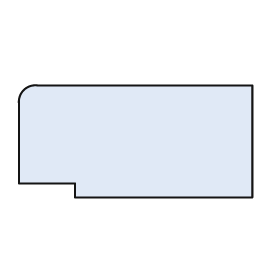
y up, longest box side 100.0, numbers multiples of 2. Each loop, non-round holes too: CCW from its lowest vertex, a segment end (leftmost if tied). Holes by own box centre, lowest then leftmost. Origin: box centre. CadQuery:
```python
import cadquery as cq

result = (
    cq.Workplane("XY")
    .moveTo(-26.0, -24.0)
    .lineTo(50.0, -24.0)
    .lineTo(50.0, 24.0)
    .lineTo(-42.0, 24.0)
    .threePointArc((-48.0, 22.0), (-50.0, 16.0))
    .lineTo(-50.0, -18.0)
    .lineTo(-26.0, -18.0)
    .close()
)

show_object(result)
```